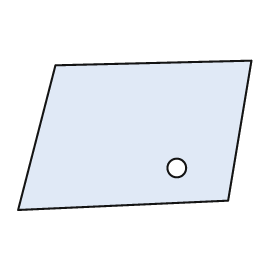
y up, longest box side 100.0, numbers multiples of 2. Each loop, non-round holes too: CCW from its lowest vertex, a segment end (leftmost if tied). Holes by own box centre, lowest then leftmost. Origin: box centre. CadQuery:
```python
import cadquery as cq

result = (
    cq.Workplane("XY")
    .moveTo(-50.0, -32.0)
    .lineTo(40.0, -28.0)
    .lineTo(50.0, 32.0)
    .lineTo(-34.0, 30.0)
    .close()
    .moveTo(18.0, -14.0)
    .circle(4.0)
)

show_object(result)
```